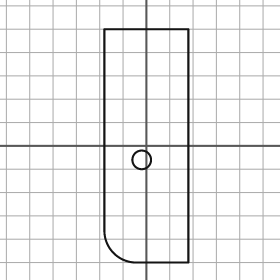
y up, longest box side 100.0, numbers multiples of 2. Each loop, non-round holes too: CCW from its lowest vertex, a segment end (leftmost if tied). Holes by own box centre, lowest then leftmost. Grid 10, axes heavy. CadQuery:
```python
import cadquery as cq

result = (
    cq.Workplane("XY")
    .moveTo(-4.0, -50.0)
    .lineTo(18.0, -50.0)
    .lineTo(18.0, 50.0)
    .lineTo(-18.0, 50.0)
    .lineTo(-18.0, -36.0)
    .threePointArc((-14.0, -46.0), (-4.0, -50.0))
    .close()
    .moveTo(-2.0, -6.0)
    .circle(4.0)
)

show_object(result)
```